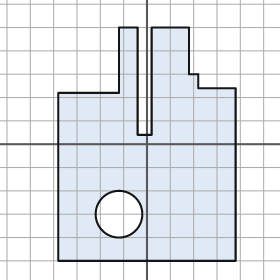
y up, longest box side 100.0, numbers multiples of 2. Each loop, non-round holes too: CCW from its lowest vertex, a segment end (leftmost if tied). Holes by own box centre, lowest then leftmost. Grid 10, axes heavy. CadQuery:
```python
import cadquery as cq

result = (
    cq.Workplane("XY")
    .moveTo(-38.0, -50.0)
    .lineTo(38.0, -50.0)
    .lineTo(38.0, 24.0)
    .lineTo(22.0, 24.0)
    .lineTo(22.0, 30.0)
    .lineTo(18.0, 30.0)
    .lineTo(18.0, 50.0)
    .lineTo(2.0, 50.0)
    .lineTo(2.0, 4.0)
    .lineTo(-4.0, 4.0)
    .lineTo(-4.0, 50.0)
    .lineTo(-12.0, 50.0)
    .lineTo(-12.0, 22.0)
    .lineTo(-38.0, 22.0)
    .close()
    .moveTo(-12.0, -30.0)
    .circle(10.0)
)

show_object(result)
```